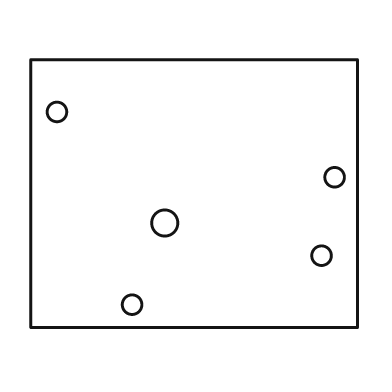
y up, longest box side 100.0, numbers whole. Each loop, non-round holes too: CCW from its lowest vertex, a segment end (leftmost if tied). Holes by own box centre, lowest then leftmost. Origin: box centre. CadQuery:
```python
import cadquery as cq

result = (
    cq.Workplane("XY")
    .moveTo(-50.0, -41.0)
    .lineTo(50.0, -41.0)
    .lineTo(50.0, 41.0)
    .lineTo(-50.0, 41.0)
    .close()
    .moveTo(-19.0, -34.0)
    .circle(3.0)
    .moveTo(39.0, -19.0)
    .circle(3.0)
    .moveTo(-9.0, -9.0)
    .circle(4.0)
    .moveTo(43.0, 5.0)
    .circle(3.0)
    .moveTo(-42.0, 25.0)
    .circle(3.0)
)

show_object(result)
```